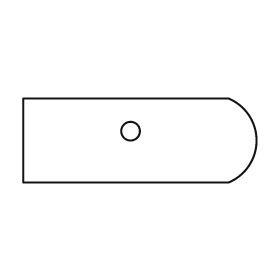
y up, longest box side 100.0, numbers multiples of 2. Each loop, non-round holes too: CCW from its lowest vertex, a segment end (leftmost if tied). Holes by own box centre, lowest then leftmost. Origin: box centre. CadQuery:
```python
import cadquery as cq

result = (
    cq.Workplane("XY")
    .moveTo(-50.0, -18.0)
    .lineTo(38.0, -18.0)
    .threePointArc((50.0, 0.0), (38.0, 18.0))
    .lineTo(-50.0, 18.0)
    .close()
    .moveTo(-4.0, 4.0)
    .circle(4.0)
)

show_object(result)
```